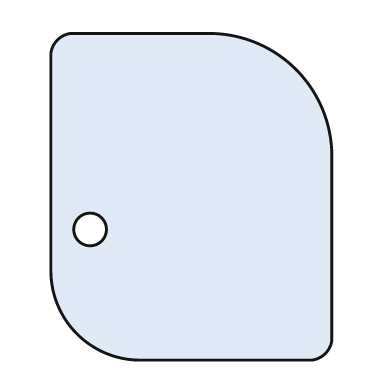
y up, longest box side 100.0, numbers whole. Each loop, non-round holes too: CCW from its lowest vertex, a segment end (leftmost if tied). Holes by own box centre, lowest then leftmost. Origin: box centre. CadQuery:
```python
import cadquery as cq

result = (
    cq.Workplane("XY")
    .moveTo(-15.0, -50.0)
    .lineTo(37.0, -50.0)
    .threePointArc((41.0, -48.0), (43.0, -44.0))
    .lineTo(43.0, 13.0)
    .threePointArc((32.0, 39.0), (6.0, 50.0))
    .lineTo(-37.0, 50.0)
    .threePointArc((-41.0, 48.0), (-43.0, 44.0))
    .lineTo(-43.0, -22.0)
    .threePointArc((-35.0, -42.0), (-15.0, -50.0))
    .close()
    .moveTo(-31.0, -10.0)
    .circle(5.0)
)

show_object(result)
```